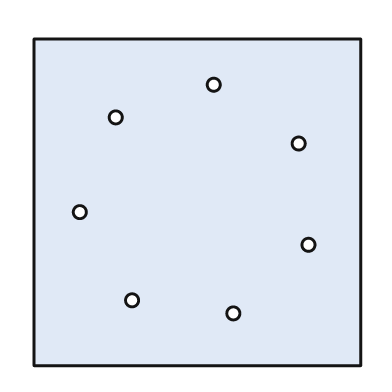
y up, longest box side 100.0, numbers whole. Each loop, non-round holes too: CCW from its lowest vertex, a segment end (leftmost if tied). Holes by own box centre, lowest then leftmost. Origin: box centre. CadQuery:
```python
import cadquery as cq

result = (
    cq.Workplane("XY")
    .moveTo(-50.0, -50.0)
    .lineTo(50.0, -50.0)
    .lineTo(50.0, 50.0)
    .lineTo(-50.0, 50.0)
    .close()
    .moveTo(11.0, -34.0)
    .circle(2.0)
    .moveTo(-20.0, -30.0)
    .circle(2.0)
    .moveTo(34.0, -13.0)
    .circle(2.0)
    .moveTo(-36.0, -3.0)
    .circle(2.0)
    .moveTo(31.0, 18.0)
    .circle(2.0)
    .moveTo(-25.0, 26.0)
    .circle(2.0)
    .moveTo(5.0, 36.0)
    .circle(2.0)
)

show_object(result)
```